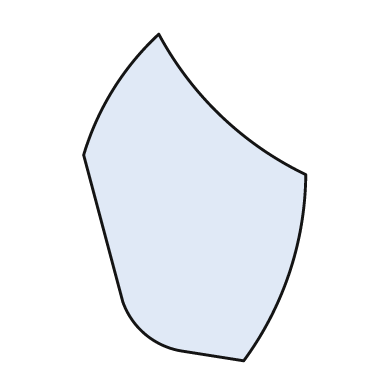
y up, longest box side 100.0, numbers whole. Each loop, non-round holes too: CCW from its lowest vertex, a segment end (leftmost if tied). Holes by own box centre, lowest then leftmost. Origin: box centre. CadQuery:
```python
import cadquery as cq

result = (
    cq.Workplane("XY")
    .moveTo(15.0, -50.0)
    .threePointArc((29.0, -23.0), (34.0, 7.0))
    .threePointArc((8.0, 25.0), (-11.0, 50.0))
    .threePointArc((-25.0, 33.0), (-34.0, 13.0))
    .lineTo(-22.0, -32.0)
    .threePointArc((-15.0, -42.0), (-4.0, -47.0))
    .close()
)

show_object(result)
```